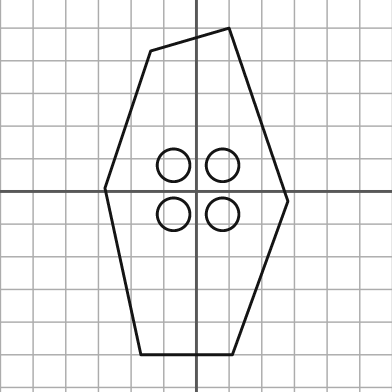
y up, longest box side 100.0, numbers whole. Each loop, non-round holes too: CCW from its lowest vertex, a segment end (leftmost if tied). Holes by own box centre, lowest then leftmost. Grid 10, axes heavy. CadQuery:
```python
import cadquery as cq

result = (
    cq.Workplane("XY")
    .moveTo(-17.0, -50.0)
    .lineTo(11.0, -50.0)
    .lineTo(28.0, -3.0)
    .lineTo(10.0, 50.0)
    .lineTo(-14.0, 43.0)
    .lineTo(-28.0, 1.0)
    .close()
    .moveTo(-7.0, -7.0)
    .circle(5.0)
    .moveTo(8.0, -7.0)
    .circle(5.0)
    .moveTo(-7.0, 8.0)
    .circle(5.0)
    .moveTo(8.0, 8.0)
    .circle(5.0)
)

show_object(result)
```